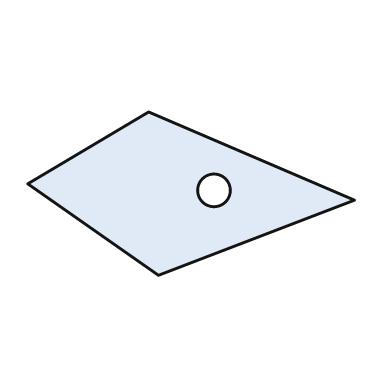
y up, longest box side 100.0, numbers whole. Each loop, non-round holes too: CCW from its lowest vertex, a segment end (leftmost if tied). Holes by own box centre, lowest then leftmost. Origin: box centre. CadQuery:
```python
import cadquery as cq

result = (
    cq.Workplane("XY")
    .moveTo(-10.0, -25.0)
    .lineTo(50.0, -2.0)
    .lineTo(-13.0, 25.0)
    .lineTo(-50.0, 3.0)
    .close()
    .moveTo(7.0, 1.0)
    .circle(5.0)
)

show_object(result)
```